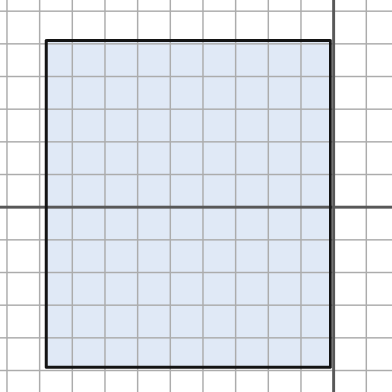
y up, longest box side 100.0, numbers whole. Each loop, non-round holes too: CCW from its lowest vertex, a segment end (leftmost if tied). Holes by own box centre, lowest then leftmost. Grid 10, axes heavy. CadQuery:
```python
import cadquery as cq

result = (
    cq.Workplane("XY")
    .moveTo(-88.0, -49.0)
    .lineTo(-1.0, -49.0)
    .lineTo(-1.0, 51.0)
    .lineTo(-88.0, 51.0)
    .close()
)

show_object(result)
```